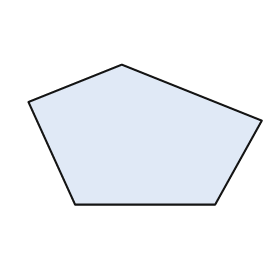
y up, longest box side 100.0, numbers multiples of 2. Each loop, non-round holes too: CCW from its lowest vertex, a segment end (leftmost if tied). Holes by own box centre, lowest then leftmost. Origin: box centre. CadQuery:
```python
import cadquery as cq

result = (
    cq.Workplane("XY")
    .moveTo(-30.0, -30.0)
    .lineTo(30.0, -30.0)
    .lineTo(50.0, 6.0)
    .lineTo(-10.0, 30.0)
    .lineTo(-50.0, 14.0)
    .close()
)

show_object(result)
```